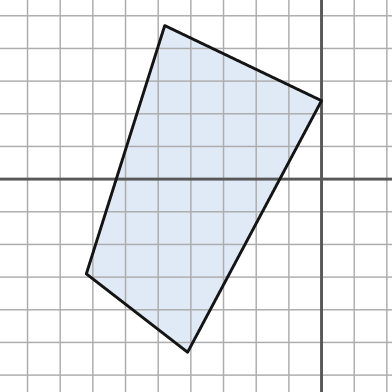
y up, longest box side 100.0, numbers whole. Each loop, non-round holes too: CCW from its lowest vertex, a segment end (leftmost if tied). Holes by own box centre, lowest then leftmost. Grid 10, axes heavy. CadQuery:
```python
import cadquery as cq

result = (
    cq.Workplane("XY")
    .moveTo(-41.0, -53.0)
    .lineTo(0.0, 24.0)
    .lineTo(-48.0, 47.0)
    .lineTo(-72.0, -29.0)
    .close()
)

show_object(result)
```